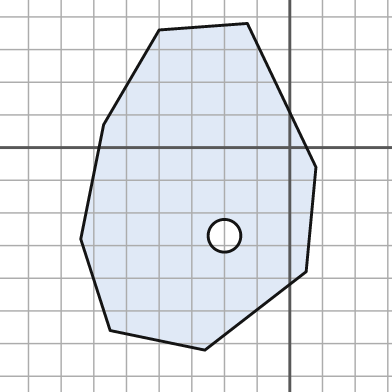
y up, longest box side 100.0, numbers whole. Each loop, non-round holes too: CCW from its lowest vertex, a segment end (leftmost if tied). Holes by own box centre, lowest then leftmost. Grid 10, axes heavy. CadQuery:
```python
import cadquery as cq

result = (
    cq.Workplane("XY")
    .moveTo(-26.0, -62.0)
    .lineTo(5.0, -38.0)
    .lineTo(8.0, -6.0)
    .lineTo(-13.0, 38.0)
    .lineTo(-40.0, 36.0)
    .lineTo(-57.0, 7.0)
    .lineTo(-64.0, -28.0)
    .lineTo(-55.0, -56.0)
    .close()
    .moveTo(-20.0, -27.0)
    .circle(5.0)
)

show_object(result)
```